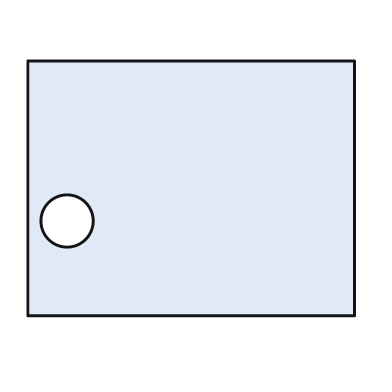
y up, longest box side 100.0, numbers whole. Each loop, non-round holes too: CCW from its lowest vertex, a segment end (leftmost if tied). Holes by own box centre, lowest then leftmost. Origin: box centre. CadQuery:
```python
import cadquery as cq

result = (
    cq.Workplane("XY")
    .moveTo(-50.0, -39.0)
    .lineTo(50.0, -39.0)
    .lineTo(50.0, 39.0)
    .lineTo(-50.0, 39.0)
    .close()
    .moveTo(-38.0, -10.0)
    .circle(8.0)
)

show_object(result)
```